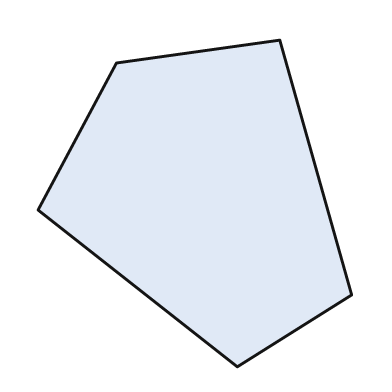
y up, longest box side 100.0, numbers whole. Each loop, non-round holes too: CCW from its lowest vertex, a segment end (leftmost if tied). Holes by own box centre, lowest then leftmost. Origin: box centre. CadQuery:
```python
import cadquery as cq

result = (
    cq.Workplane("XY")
    .moveTo(13.0, -50.0)
    .lineTo(48.0, -28.0)
    .lineTo(26.0, 50.0)
    .lineTo(-24.0, 43.0)
    .lineTo(-48.0, -2.0)
    .close()
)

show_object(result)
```